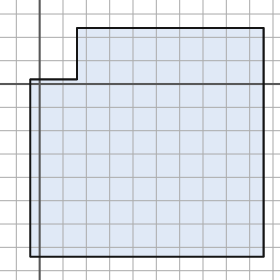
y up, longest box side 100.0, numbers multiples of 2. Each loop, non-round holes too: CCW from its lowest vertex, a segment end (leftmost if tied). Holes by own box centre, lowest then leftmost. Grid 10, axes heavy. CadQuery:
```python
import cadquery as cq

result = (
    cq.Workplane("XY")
    .moveTo(-4.0, -74.0)
    .lineTo(96.0, -74.0)
    .lineTo(96.0, 24.0)
    .lineTo(16.0, 24.0)
    .lineTo(16.0, 2.0)
    .lineTo(-4.0, 2.0)
    .close()
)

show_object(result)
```